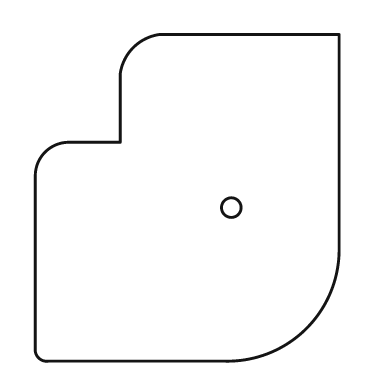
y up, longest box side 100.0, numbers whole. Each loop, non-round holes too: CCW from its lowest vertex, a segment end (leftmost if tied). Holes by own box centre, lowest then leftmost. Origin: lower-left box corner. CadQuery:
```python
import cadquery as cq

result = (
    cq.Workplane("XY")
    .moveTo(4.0, 0.0)
    .lineTo(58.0, 0.0)
    .threePointArc((83.0, 10.0), (93.0, 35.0))
    .lineTo(93.0, 100.0)
    .lineTo(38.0, 100.0)
    .threePointArc((30.0, 96.0), (26.0, 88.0))
    .lineTo(26.0, 67.0)
    .lineTo(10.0, 67.0)
    .threePointArc((3.0, 64.0), (0.0, 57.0))
    .lineTo(0.0, 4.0)
    .threePointArc((1.0, 1.0), (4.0, 0.0))
    .close()
    .moveTo(60.0, 47.0)
    .circle(3.0)
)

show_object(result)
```